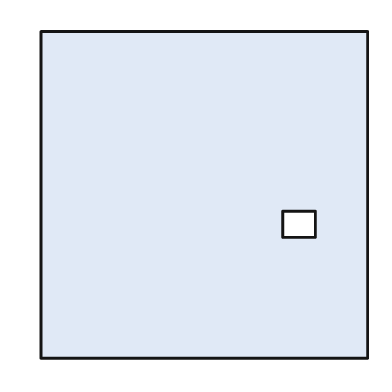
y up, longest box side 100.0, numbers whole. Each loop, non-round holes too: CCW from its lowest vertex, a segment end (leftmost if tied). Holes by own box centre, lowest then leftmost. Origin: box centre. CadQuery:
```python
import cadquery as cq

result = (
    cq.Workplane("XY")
    .moveTo(-50.0, -50.0)
    .lineTo(50.0, -50.0)
    .lineTo(50.0, 50.0)
    .lineTo(-50.0, 50.0)
    .close()
    .moveTo(24.0, -13.0)
    .lineTo(34.0, -13.0)
    .lineTo(34.0, -5.0)
    .lineTo(24.0, -5.0)
    .close()
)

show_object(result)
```